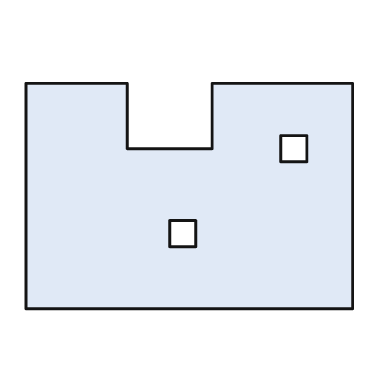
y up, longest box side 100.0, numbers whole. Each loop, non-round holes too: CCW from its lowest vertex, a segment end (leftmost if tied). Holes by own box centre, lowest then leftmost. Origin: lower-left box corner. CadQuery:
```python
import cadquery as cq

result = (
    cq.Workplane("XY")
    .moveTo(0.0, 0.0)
    .lineTo(100.0, 0.0)
    .lineTo(100.0, 69.0)
    .lineTo(57.0, 69.0)
    .lineTo(57.0, 49.0)
    .lineTo(31.0, 49.0)
    .lineTo(31.0, 69.0)
    .lineTo(0.0, 69.0)
    .close()
    .moveTo(44.0, 19.0)
    .lineTo(52.0, 19.0)
    .lineTo(52.0, 27.0)
    .lineTo(44.0, 27.0)
    .close()
    .moveTo(78.0, 45.0)
    .lineTo(86.0, 45.0)
    .lineTo(86.0, 53.0)
    .lineTo(78.0, 53.0)
    .close()
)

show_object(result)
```